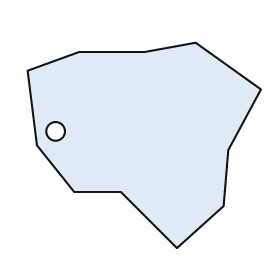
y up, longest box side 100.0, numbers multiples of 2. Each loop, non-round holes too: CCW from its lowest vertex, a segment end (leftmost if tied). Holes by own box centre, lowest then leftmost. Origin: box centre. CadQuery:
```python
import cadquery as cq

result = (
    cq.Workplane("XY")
    .moveTo(14.0, -44.0)
    .lineTo(34.0, -26.0)
    .lineTo(36.0, -2.0)
    .lineTo(50.0, 24.0)
    .lineTo(22.0, 44.0)
    .lineTo(0.0, 40.0)
    .lineTo(-28.0, 40.0)
    .lineTo(-50.0, 32.0)
    .lineTo(-46.0, 0.0)
    .lineTo(-30.0, -20.0)
    .lineTo(-10.0, -20.0)
    .close()
    .moveTo(-38.0, 6.0)
    .circle(4.0)
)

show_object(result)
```